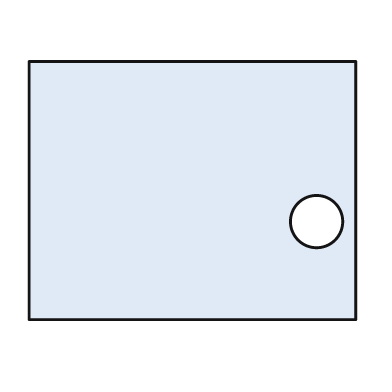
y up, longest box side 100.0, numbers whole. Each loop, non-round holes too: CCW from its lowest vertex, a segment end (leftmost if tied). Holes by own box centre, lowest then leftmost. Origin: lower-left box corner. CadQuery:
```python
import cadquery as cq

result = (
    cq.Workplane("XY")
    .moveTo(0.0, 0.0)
    .lineTo(100.0, 0.0)
    .lineTo(100.0, 79.0)
    .lineTo(0.0, 79.0)
    .close()
    .moveTo(88.0, 30.0)
    .circle(8.0)
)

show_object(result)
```